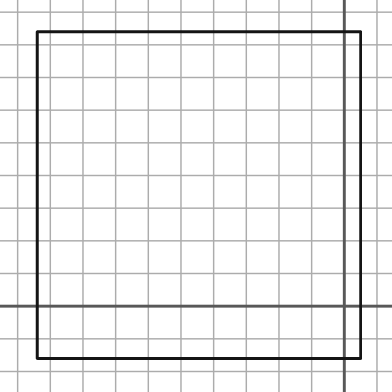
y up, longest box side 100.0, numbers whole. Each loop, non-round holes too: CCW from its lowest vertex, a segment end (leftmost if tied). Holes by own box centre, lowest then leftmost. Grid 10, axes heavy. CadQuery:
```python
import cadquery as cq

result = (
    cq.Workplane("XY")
    .moveTo(-94.0, -16.0)
    .lineTo(5.0, -16.0)
    .lineTo(5.0, 84.0)
    .lineTo(-94.0, 84.0)
    .close()
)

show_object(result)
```